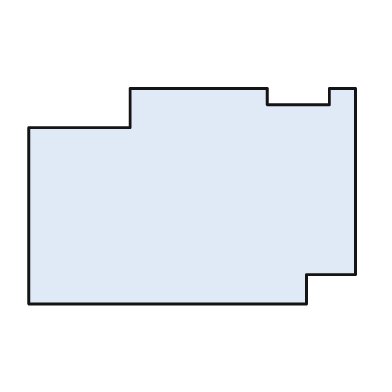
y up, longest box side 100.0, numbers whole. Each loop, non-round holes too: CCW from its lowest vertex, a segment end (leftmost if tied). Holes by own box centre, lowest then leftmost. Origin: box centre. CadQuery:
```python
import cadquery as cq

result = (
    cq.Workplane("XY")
    .moveTo(-50.0, -33.0)
    .lineTo(35.0, -33.0)
    .lineTo(35.0, -24.0)
    .lineTo(50.0, -24.0)
    .lineTo(50.0, 33.0)
    .lineTo(42.0, 33.0)
    .lineTo(42.0, 28.0)
    .lineTo(23.0, 28.0)
    .lineTo(23.0, 33.0)
    .lineTo(-19.0, 33.0)
    .lineTo(-19.0, 21.0)
    .lineTo(-50.0, 21.0)
    .close()
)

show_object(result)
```